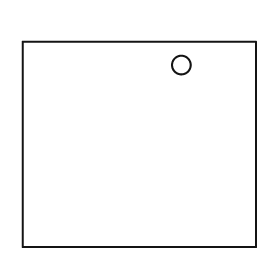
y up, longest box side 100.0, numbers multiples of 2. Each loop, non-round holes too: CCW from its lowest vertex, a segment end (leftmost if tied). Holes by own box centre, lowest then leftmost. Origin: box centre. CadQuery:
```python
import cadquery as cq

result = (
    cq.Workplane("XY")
    .moveTo(-50.0, -44.0)
    .lineTo(50.0, -44.0)
    .lineTo(50.0, 44.0)
    .lineTo(-50.0, 44.0)
    .close()
    .moveTo(18.0, 34.0)
    .circle(4.0)
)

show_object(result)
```